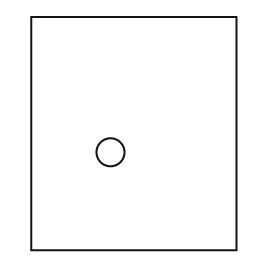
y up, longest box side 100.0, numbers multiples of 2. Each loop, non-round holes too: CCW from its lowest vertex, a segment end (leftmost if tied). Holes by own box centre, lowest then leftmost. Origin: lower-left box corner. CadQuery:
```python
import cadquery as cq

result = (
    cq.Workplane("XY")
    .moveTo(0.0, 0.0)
    .lineTo(88.0, 0.0)
    .lineTo(88.0, 100.0)
    .lineTo(0.0, 100.0)
    .close()
    .moveTo(34.0, 42.0)
    .circle(6.0)
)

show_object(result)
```